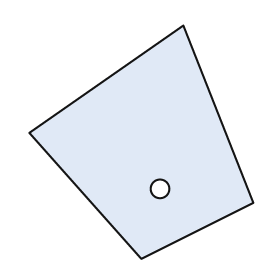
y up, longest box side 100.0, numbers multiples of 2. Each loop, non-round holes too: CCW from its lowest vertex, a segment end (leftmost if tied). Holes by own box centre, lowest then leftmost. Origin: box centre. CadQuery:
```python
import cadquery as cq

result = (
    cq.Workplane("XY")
    .moveTo(0.0, -50.0)
    .lineTo(48.0, -26.0)
    .lineTo(18.0, 50.0)
    .lineTo(-48.0, 4.0)
    .close()
    .moveTo(8.0, -20.0)
    .circle(4.0)
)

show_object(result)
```